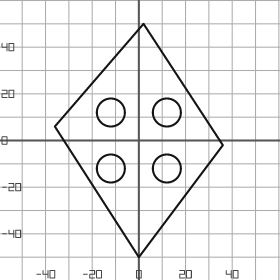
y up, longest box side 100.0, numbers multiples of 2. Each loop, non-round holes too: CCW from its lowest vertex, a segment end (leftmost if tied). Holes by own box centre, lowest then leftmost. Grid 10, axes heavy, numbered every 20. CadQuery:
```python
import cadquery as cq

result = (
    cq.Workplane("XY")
    .moveTo(0.0, -50.0)
    .lineTo(36.0, -2.0)
    .lineTo(2.0, 50.0)
    .lineTo(-36.0, 6.0)
    .close()
    .moveTo(-12.0, -12.0)
    .circle(6.0)
    .moveTo(12.0, -12.0)
    .circle(6.0)
    .moveTo(-12.0, 12.0)
    .circle(6.0)
    .moveTo(12.0, 12.0)
    .circle(6.0)
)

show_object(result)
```